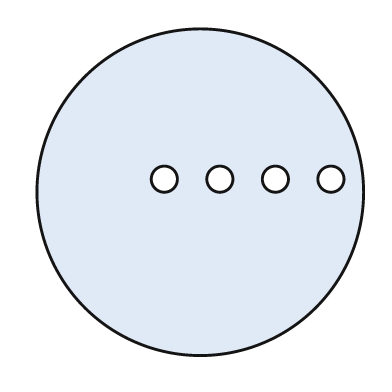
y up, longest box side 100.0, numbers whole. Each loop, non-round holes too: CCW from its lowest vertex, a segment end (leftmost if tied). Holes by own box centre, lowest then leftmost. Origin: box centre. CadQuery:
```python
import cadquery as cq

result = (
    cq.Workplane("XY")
    .moveTo(0.0, 0.0)
    .circle(50.0)
    .moveTo(-11.0, 4.0)
    .circle(4.0)
    .moveTo(6.0, 4.0)
    .circle(4.0)
    .moveTo(23.0, 4.0)
    .circle(4.0)
    .moveTo(40.0, 4.0)
    .circle(4.0)
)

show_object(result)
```